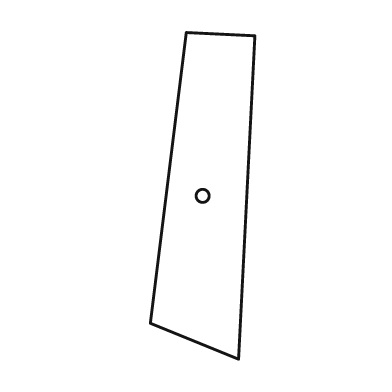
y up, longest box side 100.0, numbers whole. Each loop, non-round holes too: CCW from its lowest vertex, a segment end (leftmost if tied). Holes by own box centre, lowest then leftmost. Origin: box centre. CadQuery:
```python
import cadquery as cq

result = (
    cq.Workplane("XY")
    .moveTo(11.0, -50.0)
    .lineTo(16.0, 49.0)
    .lineTo(-5.0, 50.0)
    .lineTo(-16.0, -39.0)
    .close()
    .moveTo(0.0, 0.0)
    .circle(2.0)
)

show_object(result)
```